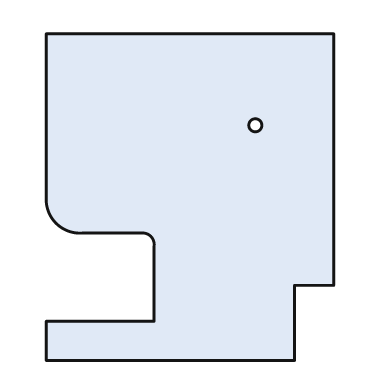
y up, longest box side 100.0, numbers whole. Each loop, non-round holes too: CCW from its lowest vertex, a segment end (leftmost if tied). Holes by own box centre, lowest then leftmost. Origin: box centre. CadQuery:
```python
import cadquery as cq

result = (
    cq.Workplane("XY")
    .moveTo(-44.0, -50.0)
    .lineTo(32.0, -50.0)
    .lineTo(32.0, -27.0)
    .lineTo(44.0, -27.0)
    .lineTo(44.0, 50.0)
    .lineTo(-44.0, 50.0)
    .lineTo(-44.0, 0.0)
    .threePointArc((-41.0, -8.0), (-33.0, -11.0))
    .lineTo(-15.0, -11.0)
    .threePointArc((-12.0, -12.0), (-11.0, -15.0))
    .lineTo(-11.0, -38.0)
    .lineTo(-44.0, -38.0)
    .close()
    .moveTo(20.0, 22.0)
    .circle(2.0)
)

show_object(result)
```